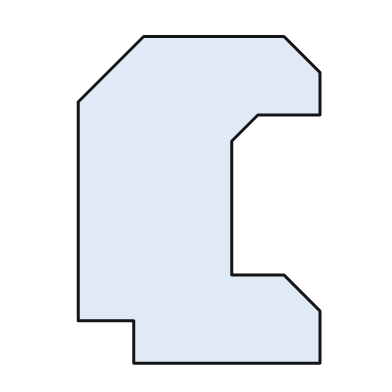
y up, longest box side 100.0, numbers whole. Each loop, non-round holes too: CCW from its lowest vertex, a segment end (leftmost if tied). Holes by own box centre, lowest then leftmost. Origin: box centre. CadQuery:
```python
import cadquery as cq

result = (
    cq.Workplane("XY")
    .moveTo(-20.0, -50.0)
    .lineTo(37.0, -50.0)
    .lineTo(37.0, -34.0)
    .lineTo(26.0, -23.0)
    .lineTo(10.0, -23.0)
    .lineTo(10.0, 18.0)
    .lineTo(18.0, 26.0)
    .lineTo(37.0, 26.0)
    .lineTo(37.0, 39.0)
    .lineTo(26.0, 50.0)
    .lineTo(-17.0, 50.0)
    .lineTo(-37.0, 30.0)
    .lineTo(-37.0, -37.0)
    .lineTo(-20.0, -37.0)
    .close()
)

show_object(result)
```